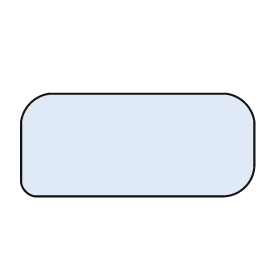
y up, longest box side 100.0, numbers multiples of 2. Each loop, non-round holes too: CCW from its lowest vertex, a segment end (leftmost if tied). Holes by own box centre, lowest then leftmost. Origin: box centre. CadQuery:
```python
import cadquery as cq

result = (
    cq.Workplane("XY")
    .moveTo(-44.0, -22.0)
    .lineTo(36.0, -22.0)
    .threePointArc((46.0, -18.0), (50.0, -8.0))
    .lineTo(50.0, 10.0)
    .threePointArc((46.0, 18.0), (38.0, 22.0))
    .lineTo(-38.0, 22.0)
    .threePointArc((-46.0, 18.0), (-50.0, 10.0))
    .lineTo(-50.0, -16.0)
    .threePointArc((-48.0, -20.0), (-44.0, -22.0))
    .close()
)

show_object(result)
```